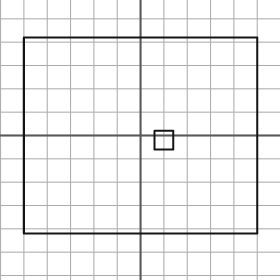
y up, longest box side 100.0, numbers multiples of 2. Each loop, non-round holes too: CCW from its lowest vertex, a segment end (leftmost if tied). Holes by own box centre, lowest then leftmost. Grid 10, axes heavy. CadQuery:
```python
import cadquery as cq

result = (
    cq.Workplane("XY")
    .moveTo(-50.0, -42.0)
    .lineTo(50.0, -42.0)
    .lineTo(50.0, 42.0)
    .lineTo(-50.0, 42.0)
    .close()
    .moveTo(6.0, -6.0)
    .lineTo(14.0, -6.0)
    .lineTo(14.0, 2.0)
    .lineTo(6.0, 2.0)
    .close()
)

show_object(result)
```